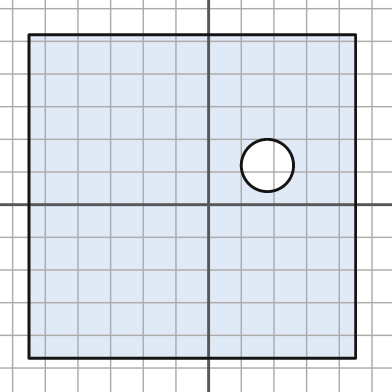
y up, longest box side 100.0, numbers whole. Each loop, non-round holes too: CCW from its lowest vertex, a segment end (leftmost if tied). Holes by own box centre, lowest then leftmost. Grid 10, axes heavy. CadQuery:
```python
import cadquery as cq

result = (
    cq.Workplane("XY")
    .moveTo(-55.0, -47.0)
    .lineTo(45.0, -47.0)
    .lineTo(45.0, 52.0)
    .lineTo(-55.0, 52.0)
    .close()
    .moveTo(18.0, 12.0)
    .circle(8.0)
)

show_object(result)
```